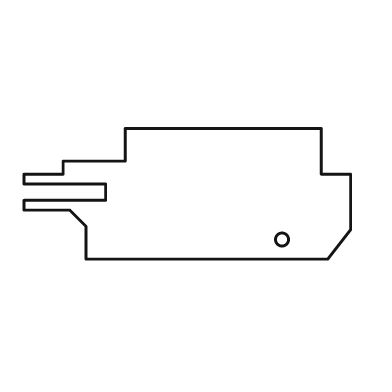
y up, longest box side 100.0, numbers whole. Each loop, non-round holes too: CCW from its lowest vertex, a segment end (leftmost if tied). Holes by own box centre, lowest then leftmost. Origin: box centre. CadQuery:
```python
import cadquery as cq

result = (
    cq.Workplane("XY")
    .moveTo(-31.0, -20.0)
    .lineTo(43.0, -20.0)
    .lineTo(50.0, -11.0)
    .lineTo(50.0, 6.0)
    .lineTo(41.0, 6.0)
    .lineTo(41.0, 20.0)
    .lineTo(-19.0, 20.0)
    .lineTo(-19.0, 10.0)
    .lineTo(-38.0, 10.0)
    .lineTo(-38.0, 6.0)
    .lineTo(-50.0, 6.0)
    .lineTo(-50.0, 3.0)
    .lineTo(-25.0, 3.0)
    .lineTo(-25.0, -2.0)
    .lineTo(-50.0, -2.0)
    .lineTo(-50.0, -5.0)
    .lineTo(-36.0, -5.0)
    .lineTo(-31.0, -10.0)
    .close()
    .moveTo(29.0, -14.0)
    .circle(2.0)
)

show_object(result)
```